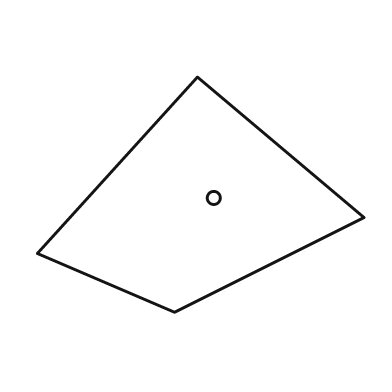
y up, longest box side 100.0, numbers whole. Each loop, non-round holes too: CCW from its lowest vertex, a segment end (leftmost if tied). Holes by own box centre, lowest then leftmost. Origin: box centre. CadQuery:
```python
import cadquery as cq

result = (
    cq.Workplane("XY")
    .moveTo(-8.0, -36.0)
    .lineTo(50.0, -7.0)
    .lineTo(-1.0, 36.0)
    .lineTo(-50.0, -18.0)
    .close()
    .moveTo(4.0, -1.0)
    .circle(2.0)
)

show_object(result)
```